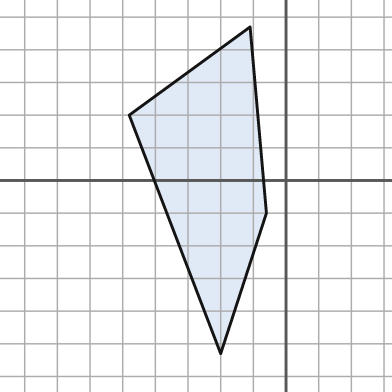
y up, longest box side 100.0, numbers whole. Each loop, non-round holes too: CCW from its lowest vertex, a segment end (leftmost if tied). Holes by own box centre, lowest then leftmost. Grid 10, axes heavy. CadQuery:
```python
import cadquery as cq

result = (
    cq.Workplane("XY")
    .moveTo(-20.0, -53.0)
    .lineTo(-6.0, -10.0)
    .lineTo(-11.0, 47.0)
    .lineTo(-48.0, 20.0)
    .close()
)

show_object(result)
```